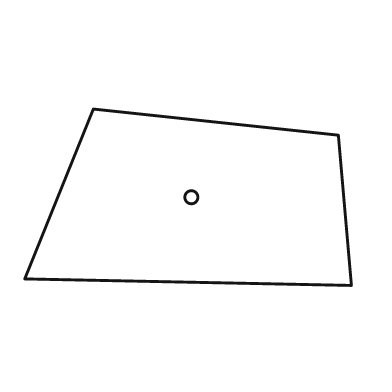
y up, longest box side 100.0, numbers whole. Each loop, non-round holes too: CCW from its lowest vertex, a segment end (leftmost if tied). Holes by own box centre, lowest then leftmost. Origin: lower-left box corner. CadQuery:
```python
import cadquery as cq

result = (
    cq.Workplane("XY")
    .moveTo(100.0, 0.0)
    .lineTo(96.0, 46.0)
    .lineTo(21.0, 54.0)
    .lineTo(0.0, 2.0)
    .close()
    .moveTo(51.0, 27.0)
    .circle(2.0)
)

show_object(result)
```